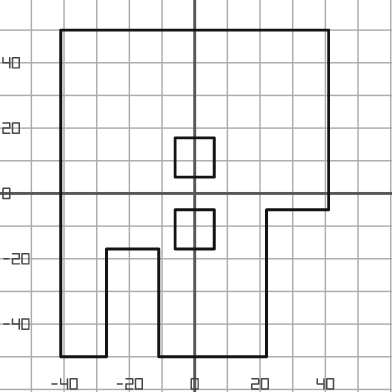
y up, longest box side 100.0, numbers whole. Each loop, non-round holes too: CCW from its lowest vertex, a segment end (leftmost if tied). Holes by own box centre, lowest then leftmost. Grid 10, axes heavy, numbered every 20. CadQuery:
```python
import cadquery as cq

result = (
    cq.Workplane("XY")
    .moveTo(-41.0, -50.0)
    .lineTo(-27.0, -50.0)
    .lineTo(-27.0, -17.0)
    .lineTo(-11.0, -17.0)
    .lineTo(-11.0, -50.0)
    .lineTo(22.0, -50.0)
    .lineTo(22.0, -5.0)
    .lineTo(41.0, -5.0)
    .lineTo(41.0, 50.0)
    .lineTo(-41.0, 50.0)
    .close()
    .moveTo(-6.0, -17.0)
    .lineTo(6.0, -17.0)
    .lineTo(6.0, -5.0)
    .lineTo(-6.0, -5.0)
    .close()
    .moveTo(-6.0, 5.0)
    .lineTo(6.0, 5.0)
    .lineTo(6.0, 17.0)
    .lineTo(-6.0, 17.0)
    .close()
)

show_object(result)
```